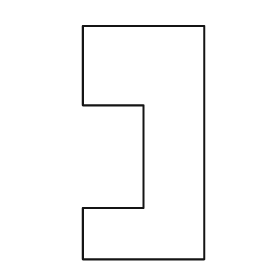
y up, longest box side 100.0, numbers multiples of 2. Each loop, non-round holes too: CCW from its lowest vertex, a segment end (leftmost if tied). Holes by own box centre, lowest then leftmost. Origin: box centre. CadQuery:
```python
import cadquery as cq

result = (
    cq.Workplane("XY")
    .moveTo(-26.0, -50.0)
    .lineTo(26.0, -50.0)
    .lineTo(26.0, 50.0)
    .lineTo(-26.0, 50.0)
    .lineTo(-26.0, 16.0)
    .lineTo(0.0, 16.0)
    .lineTo(0.0, -28.0)
    .lineTo(-26.0, -28.0)
    .close()
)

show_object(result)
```